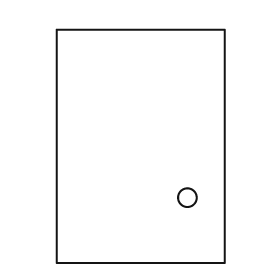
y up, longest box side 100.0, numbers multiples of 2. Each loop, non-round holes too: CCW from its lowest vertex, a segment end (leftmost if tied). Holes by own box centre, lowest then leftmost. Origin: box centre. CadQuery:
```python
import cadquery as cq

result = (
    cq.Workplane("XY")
    .moveTo(-36.0, -50.0)
    .lineTo(36.0, -50.0)
    .lineTo(36.0, 50.0)
    .lineTo(-36.0, 50.0)
    .close()
    .moveTo(20.0, -22.0)
    .circle(4.0)
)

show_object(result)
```